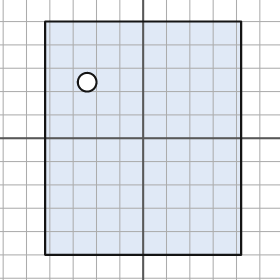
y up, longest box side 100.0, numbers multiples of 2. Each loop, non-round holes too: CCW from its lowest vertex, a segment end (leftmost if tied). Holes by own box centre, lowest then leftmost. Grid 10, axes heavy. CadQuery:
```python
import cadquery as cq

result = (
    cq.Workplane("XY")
    .moveTo(-42.0, -50.0)
    .lineTo(42.0, -50.0)
    .lineTo(42.0, 50.0)
    .lineTo(-42.0, 50.0)
    .close()
    .moveTo(-24.0, 24.0)
    .circle(4.0)
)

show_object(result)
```